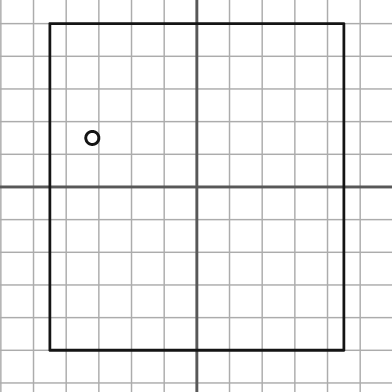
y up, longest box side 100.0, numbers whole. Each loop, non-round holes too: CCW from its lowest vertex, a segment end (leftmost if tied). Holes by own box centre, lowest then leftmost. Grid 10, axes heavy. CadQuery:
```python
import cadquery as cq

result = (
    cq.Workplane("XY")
    .moveTo(-45.0, -50.0)
    .lineTo(45.0, -50.0)
    .lineTo(45.0, 50.0)
    .lineTo(-45.0, 50.0)
    .close()
    .moveTo(-32.0, 15.0)
    .circle(2.0)
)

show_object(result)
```